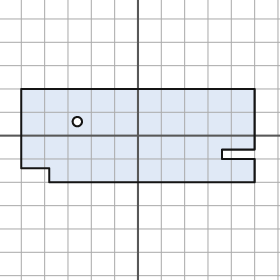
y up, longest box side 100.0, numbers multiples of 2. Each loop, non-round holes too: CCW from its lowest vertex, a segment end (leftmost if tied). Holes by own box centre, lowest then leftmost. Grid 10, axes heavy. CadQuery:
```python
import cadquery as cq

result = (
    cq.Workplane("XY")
    .moveTo(-38.0, -20.0)
    .lineTo(50.0, -20.0)
    .lineTo(50.0, -10.0)
    .lineTo(36.0, -10.0)
    .lineTo(36.0, -6.0)
    .lineTo(50.0, -6.0)
    .lineTo(50.0, 20.0)
    .lineTo(-50.0, 20.0)
    .lineTo(-50.0, -14.0)
    .lineTo(-38.0, -14.0)
    .close()
    .moveTo(-26.0, 6.0)
    .circle(2.0)
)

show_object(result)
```